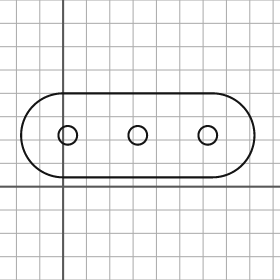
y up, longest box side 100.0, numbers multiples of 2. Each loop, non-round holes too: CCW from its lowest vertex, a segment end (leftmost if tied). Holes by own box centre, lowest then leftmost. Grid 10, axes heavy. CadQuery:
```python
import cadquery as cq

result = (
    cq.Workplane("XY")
    .moveTo(0.0, 4.0)
    .lineTo(64.0, 4.0)
    .threePointArc((82.0, 22.0), (64.0, 40.0))
    .lineTo(0.0, 40.0)
    .threePointArc((-18.0, 22.0), (0.0, 4.0))
    .close()
    .moveTo(2.0, 22.0)
    .circle(4.0)
    .moveTo(32.0, 22.0)
    .circle(4.0)
    .moveTo(62.0, 22.0)
    .circle(4.0)
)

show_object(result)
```